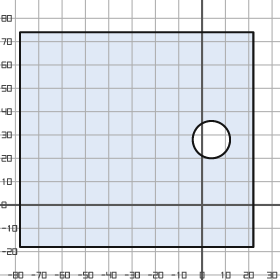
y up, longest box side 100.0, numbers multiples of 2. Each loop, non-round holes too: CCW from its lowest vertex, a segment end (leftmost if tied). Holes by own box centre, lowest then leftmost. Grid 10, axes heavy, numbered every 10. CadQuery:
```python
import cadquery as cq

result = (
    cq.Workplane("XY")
    .moveTo(-78.0, -18.0)
    .lineTo(22.0, -18.0)
    .lineTo(22.0, 74.0)
    .lineTo(-78.0, 74.0)
    .close()
    .moveTo(4.0, 28.0)
    .circle(8.0)
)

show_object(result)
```